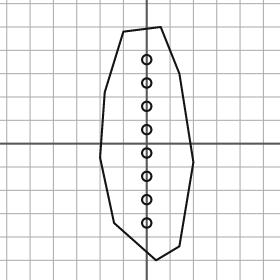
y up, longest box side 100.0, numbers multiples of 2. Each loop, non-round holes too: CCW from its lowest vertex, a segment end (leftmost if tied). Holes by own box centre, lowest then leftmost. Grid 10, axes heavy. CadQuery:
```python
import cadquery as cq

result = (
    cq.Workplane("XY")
    .moveTo(4.0, -50.0)
    .lineTo(14.0, -44.0)
    .lineTo(20.0, -8.0)
    .lineTo(14.0, 30.0)
    .lineTo(6.0, 50.0)
    .lineTo(-10.0, 48.0)
    .lineTo(-18.0, 22.0)
    .lineTo(-20.0, -6.0)
    .lineTo(-14.0, -34.0)
    .close()
    .moveTo(0.0, -34.0)
    .circle(2.0)
    .moveTo(0.0, -24.0)
    .circle(2.0)
    .moveTo(0.0, -14.0)
    .circle(2.0)
    .moveTo(0.0, -4.0)
    .circle(2.0)
    .moveTo(0.0, 6.0)
    .circle(2.0)
    .moveTo(0.0, 16.0)
    .circle(2.0)
    .moveTo(0.0, 26.0)
    .circle(2.0)
    .moveTo(0.0, 36.0)
    .circle(2.0)
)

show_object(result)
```